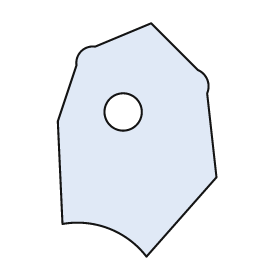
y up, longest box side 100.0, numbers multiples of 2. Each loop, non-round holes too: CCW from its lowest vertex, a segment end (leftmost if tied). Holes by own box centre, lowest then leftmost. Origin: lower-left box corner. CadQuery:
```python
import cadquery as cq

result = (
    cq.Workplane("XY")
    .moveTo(38.0, 0.0)
    .lineTo(68.0, 34.0)
    .lineTo(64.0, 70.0)
    .threePointArc((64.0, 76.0), (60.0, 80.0))
    .lineTo(40.0, 100.0)
    .lineTo(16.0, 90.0)
    .threePointArc((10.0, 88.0), (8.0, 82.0))
    .lineTo(0.0, 58.0)
    .lineTo(2.0, 14.0)
    .threePointArc((22.0, 12.0), (38.0, 0.0))
    .close()
    .moveTo(28.0, 62.0)
    .circle(8.0)
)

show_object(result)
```